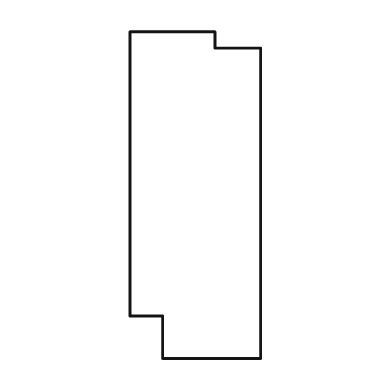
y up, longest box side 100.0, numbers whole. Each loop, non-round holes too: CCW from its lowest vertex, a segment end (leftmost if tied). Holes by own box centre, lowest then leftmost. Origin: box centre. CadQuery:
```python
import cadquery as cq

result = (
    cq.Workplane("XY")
    .moveTo(-10.0, -50.0)
    .lineTo(20.0, -50.0)
    .lineTo(20.0, 45.0)
    .lineTo(6.0, 45.0)
    .lineTo(6.0, 50.0)
    .lineTo(-20.0, 50.0)
    .lineTo(-20.0, -37.0)
    .lineTo(-10.0, -37.0)
    .close()
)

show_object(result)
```